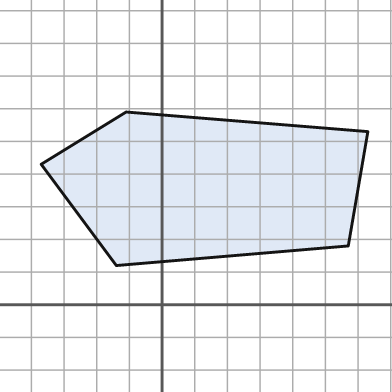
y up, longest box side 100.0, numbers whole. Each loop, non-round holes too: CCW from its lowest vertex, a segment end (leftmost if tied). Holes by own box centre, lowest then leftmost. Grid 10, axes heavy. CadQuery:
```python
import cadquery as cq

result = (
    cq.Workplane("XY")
    .moveTo(-14.0, 12.0)
    .lineTo(57.0, 18.0)
    .lineTo(63.0, 53.0)
    .lineTo(-11.0, 59.0)
    .lineTo(-37.0, 43.0)
    .close()
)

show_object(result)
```